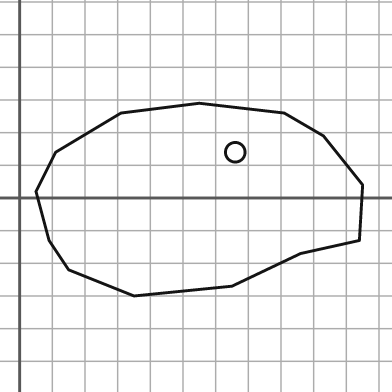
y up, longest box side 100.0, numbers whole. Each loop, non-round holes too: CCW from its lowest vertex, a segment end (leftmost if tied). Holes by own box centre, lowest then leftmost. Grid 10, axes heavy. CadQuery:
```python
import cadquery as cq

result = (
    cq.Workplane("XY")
    .moveTo(35.0, -30.0)
    .lineTo(65.0, -27.0)
    .lineTo(86.0, -17.0)
    .lineTo(104.0, -13.0)
    .lineTo(105.0, 4.0)
    .lineTo(93.0, 19.0)
    .lineTo(81.0, 26.0)
    .lineTo(55.0, 29.0)
    .lineTo(31.0, 26.0)
    .lineTo(11.0, 14.0)
    .lineTo(5.0, 2.0)
    .lineTo(9.0, -13.0)
    .lineTo(15.0, -22.0)
    .close()
    .moveTo(66.0, 14.0)
    .circle(3.0)
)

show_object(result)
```